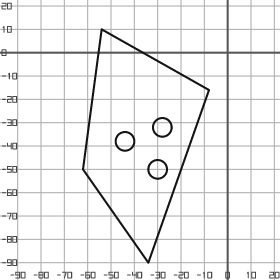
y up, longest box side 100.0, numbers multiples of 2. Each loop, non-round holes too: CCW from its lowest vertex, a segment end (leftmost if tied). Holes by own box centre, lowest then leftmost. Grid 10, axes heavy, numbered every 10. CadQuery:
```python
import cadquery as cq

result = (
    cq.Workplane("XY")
    .moveTo(-34.0, -90.0)
    .lineTo(-8.0, -16.0)
    .lineTo(-54.0, 10.0)
    .lineTo(-62.0, -50.0)
    .close()
    .moveTo(-30.0, -50.0)
    .circle(4.0)
    .moveTo(-44.0, -38.0)
    .circle(4.0)
    .moveTo(-28.0, -32.0)
    .circle(4.0)
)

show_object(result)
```